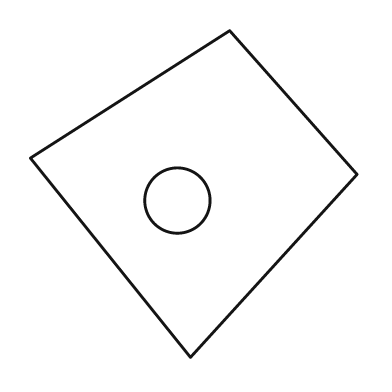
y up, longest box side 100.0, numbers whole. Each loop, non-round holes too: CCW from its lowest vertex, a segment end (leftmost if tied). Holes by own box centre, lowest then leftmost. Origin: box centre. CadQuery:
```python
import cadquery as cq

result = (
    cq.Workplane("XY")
    .moveTo(-1.0, -50.0)
    .lineTo(50.0, 6.0)
    .lineTo(11.0, 50.0)
    .lineTo(-50.0, 11.0)
    .close()
    .moveTo(-5.0, -2.0)
    .circle(10.0)
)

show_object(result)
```